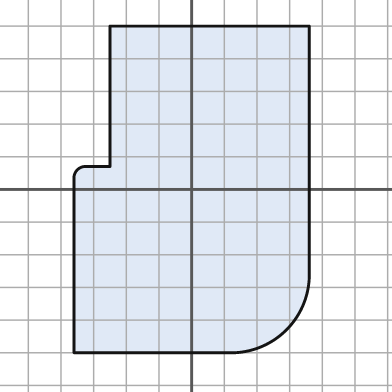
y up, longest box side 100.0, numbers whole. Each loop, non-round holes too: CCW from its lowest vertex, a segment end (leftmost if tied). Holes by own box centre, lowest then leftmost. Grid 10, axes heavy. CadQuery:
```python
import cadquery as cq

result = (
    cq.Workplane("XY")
    .moveTo(-36.0, -50.0)
    .lineTo(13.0, -50.0)
    .threePointArc((29.0, -43.0), (36.0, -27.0))
    .lineTo(36.0, 50.0)
    .lineTo(-25.0, 50.0)
    .lineTo(-25.0, 7.0)
    .lineTo(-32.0, 7.0)
    .threePointArc((-35.0, 6.0), (-36.0, 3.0))
    .close()
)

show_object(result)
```